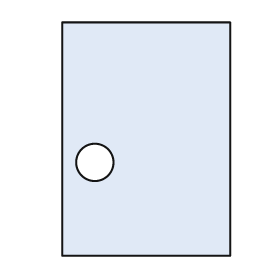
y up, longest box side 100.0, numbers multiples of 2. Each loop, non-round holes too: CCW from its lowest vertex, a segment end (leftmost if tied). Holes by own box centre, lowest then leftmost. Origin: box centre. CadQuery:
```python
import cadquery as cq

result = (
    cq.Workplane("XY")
    .moveTo(-36.0, -50.0)
    .lineTo(36.0, -50.0)
    .lineTo(36.0, 50.0)
    .lineTo(-36.0, 50.0)
    .close()
    .moveTo(-22.0, -10.0)
    .circle(8.0)
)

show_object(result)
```